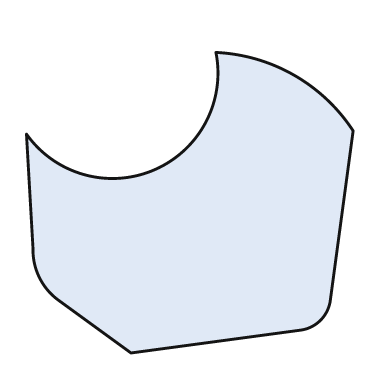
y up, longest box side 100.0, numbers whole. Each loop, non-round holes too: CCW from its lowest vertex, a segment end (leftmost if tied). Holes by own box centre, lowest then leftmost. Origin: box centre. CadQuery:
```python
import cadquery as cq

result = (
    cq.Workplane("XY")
    .moveTo(-18.0, -46.0)
    .lineTo(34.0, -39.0)
    .threePointArc((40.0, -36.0), (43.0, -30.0))
    .lineTo(50.0, 22.0)
    .threePointArc((32.0, 39.0), (8.0, 46.0))
    .threePointArc((-11.0, 10.0), (-50.0, 21.0))
    .lineTo(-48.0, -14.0)
    .threePointArc((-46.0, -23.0), (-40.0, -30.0))
    .close()
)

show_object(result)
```